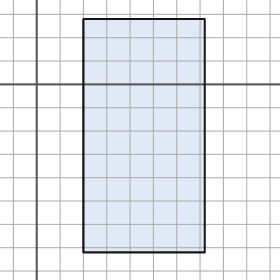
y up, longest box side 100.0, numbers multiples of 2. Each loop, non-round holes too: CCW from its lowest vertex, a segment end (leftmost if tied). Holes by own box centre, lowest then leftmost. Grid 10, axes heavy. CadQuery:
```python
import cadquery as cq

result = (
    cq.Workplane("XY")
    .moveTo(20.0, -72.0)
    .lineTo(72.0, -72.0)
    .lineTo(72.0, 28.0)
    .lineTo(20.0, 28.0)
    .close()
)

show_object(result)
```